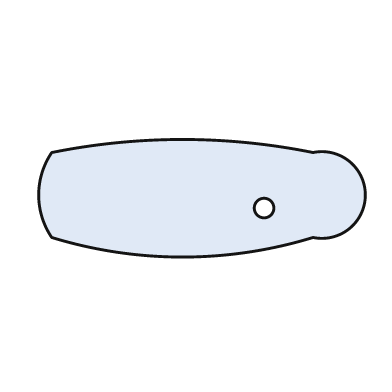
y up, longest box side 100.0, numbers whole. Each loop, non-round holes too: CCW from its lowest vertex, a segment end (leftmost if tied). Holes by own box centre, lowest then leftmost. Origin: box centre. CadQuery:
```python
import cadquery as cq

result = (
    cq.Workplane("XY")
    .moveTo(-46.0, -12.0)
    .threePointArc((-6.0, -18.0), (34.0, -12.0))
    .threePointArc((50.0, 1.0), (34.0, 14.0))
    .threePointArc((-6.0, 18.0), (-46.0, 14.0))
    .threePointArc((-50.0, 1.0), (-46.0, -12.0))
    .close()
    .moveTo(19.0, -3.0)
    .circle(3.0)
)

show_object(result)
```